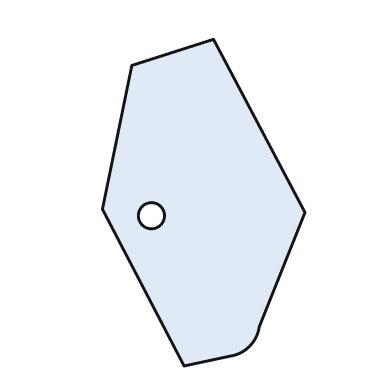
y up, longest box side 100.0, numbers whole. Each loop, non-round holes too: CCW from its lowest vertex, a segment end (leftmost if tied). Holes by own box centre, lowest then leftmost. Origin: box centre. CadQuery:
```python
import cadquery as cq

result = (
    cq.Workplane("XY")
    .moveTo(-6.0, -50.0)
    .lineTo(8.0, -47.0)
    .threePointArc((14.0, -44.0), (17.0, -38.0))
    .lineTo(31.0, -3.0)
    .lineTo(3.0, 50.0)
    .lineTo(-22.0, 42.0)
    .lineTo(-31.0, -2.0)
    .close()
    .moveTo(-16.0, -4.0)
    .circle(4.0)
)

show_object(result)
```